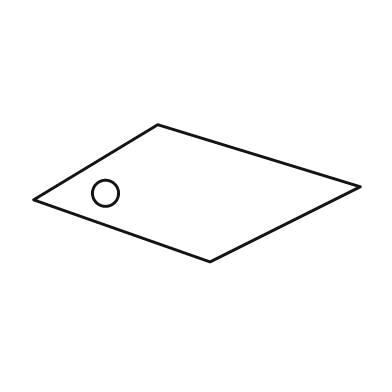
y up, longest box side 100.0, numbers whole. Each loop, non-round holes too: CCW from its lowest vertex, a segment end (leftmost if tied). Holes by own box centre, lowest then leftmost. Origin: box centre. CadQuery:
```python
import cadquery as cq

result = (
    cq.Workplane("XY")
    .moveTo(4.0, -21.0)
    .lineTo(50.0, 2.0)
    .lineTo(-12.0, 21.0)
    .lineTo(-50.0, -2.0)
    .close()
    .moveTo(-28.0, 0.0)
    .circle(4.0)
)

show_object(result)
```